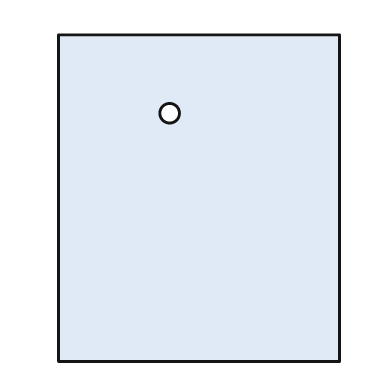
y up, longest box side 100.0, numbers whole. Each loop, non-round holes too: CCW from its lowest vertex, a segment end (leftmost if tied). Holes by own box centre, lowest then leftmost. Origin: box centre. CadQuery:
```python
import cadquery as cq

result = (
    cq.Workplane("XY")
    .moveTo(-43.0, -50.0)
    .lineTo(43.0, -50.0)
    .lineTo(43.0, 50.0)
    .lineTo(-43.0, 50.0)
    .close()
    .moveTo(-9.0, 26.0)
    .circle(3.0)
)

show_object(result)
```